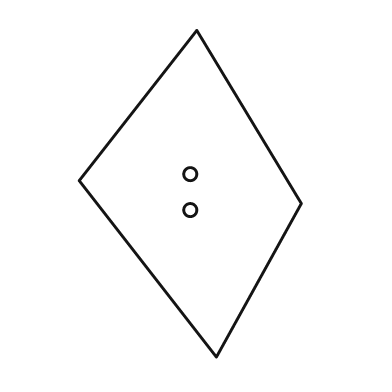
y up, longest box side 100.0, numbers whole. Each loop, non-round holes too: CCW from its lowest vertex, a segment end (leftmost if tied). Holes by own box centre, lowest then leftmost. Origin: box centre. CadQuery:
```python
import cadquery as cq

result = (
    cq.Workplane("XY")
    .moveTo(8.0, -50.0)
    .lineTo(34.0, -3.0)
    .lineTo(2.0, 50.0)
    .lineTo(-34.0, 4.0)
    .close()
    .moveTo(0.0, -5.0)
    .circle(2.0)
    .moveTo(0.0, 6.0)
    .circle(2.0)
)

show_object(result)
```